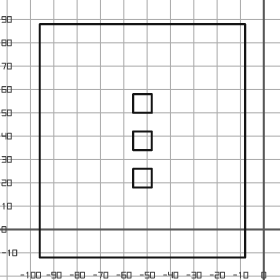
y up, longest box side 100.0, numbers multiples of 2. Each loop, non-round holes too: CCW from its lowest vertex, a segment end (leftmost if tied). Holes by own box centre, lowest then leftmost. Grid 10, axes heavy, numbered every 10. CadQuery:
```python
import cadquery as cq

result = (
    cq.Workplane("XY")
    .moveTo(-96.0, -12.0)
    .lineTo(-8.0, -12.0)
    .lineTo(-8.0, 88.0)
    .lineTo(-96.0, 88.0)
    .close()
    .moveTo(-56.0, 18.0)
    .lineTo(-48.0, 18.0)
    .lineTo(-48.0, 26.0)
    .lineTo(-56.0, 26.0)
    .close()
    .moveTo(-56.0, 34.0)
    .lineTo(-48.0, 34.0)
    .lineTo(-48.0, 42.0)
    .lineTo(-56.0, 42.0)
    .close()
    .moveTo(-56.0, 50.0)
    .lineTo(-48.0, 50.0)
    .lineTo(-48.0, 58.0)
    .lineTo(-56.0, 58.0)
    .close()
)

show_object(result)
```